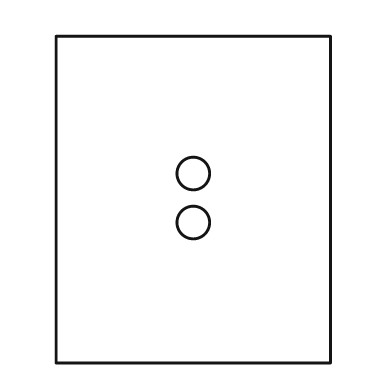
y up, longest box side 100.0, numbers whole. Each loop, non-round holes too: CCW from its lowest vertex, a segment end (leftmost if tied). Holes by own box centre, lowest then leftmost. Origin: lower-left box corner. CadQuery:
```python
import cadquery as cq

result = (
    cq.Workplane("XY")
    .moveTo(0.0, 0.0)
    .lineTo(84.0, 0.0)
    .lineTo(84.0, 100.0)
    .lineTo(0.0, 100.0)
    .close()
    .moveTo(42.0, 43.0)
    .circle(5.0)
    .moveTo(42.0, 58.0)
    .circle(5.0)
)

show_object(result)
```